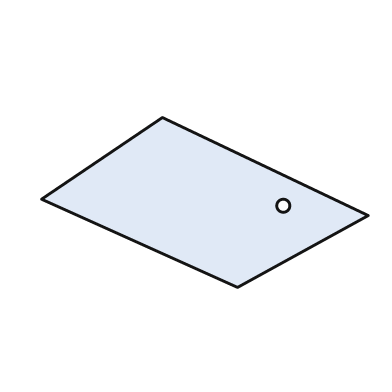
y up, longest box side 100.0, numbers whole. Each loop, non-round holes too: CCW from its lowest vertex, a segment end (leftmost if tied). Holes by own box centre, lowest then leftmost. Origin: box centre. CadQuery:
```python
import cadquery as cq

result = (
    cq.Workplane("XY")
    .moveTo(10.0, -26.0)
    .lineTo(50.0, -4.0)
    .lineTo(-13.0, 26.0)
    .lineTo(-50.0, 1.0)
    .close()
    .moveTo(24.0, -1.0)
    .circle(2.0)
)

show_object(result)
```